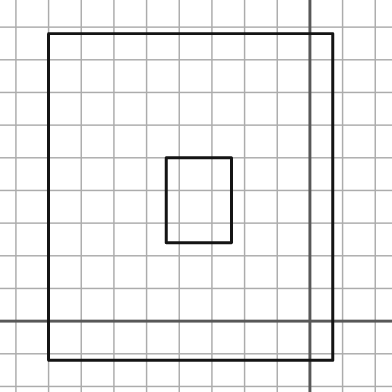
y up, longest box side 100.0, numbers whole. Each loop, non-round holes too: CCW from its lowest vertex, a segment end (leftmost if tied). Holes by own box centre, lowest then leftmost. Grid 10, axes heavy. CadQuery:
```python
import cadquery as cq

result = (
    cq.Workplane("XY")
    .moveTo(-80.0, -12.0)
    .lineTo(7.0, -12.0)
    .lineTo(7.0, 88.0)
    .lineTo(-80.0, 88.0)
    .close()
    .moveTo(-44.0, 24.0)
    .lineTo(-24.0, 24.0)
    .lineTo(-24.0, 50.0)
    .lineTo(-44.0, 50.0)
    .close()
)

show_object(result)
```